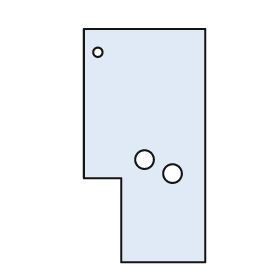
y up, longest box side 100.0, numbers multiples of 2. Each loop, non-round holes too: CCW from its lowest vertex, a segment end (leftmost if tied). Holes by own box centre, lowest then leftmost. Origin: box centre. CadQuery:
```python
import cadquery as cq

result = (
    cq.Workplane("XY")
    .moveTo(-10.0, -50.0)
    .lineTo(26.0, -50.0)
    .lineTo(26.0, 50.0)
    .lineTo(-26.0, 50.0)
    .lineTo(-26.0, -14.0)
    .lineTo(-10.0, -14.0)
    .close()
    .moveTo(12.0, -12.0)
    .circle(4.0)
    .moveTo(0.0, -6.0)
    .circle(4.0)
    .moveTo(-20.0, 40.0)
    .circle(2.0)
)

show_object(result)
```